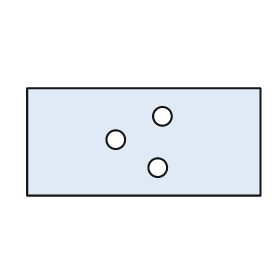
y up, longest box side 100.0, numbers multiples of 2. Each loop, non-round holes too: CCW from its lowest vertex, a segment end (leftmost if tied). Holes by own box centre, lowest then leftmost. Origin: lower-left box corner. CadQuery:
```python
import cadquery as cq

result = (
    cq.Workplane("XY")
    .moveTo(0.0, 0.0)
    .lineTo(100.0, 0.0)
    .lineTo(100.0, 46.0)
    .lineTo(0.0, 46.0)
    .close()
    .moveTo(56.0, 12.0)
    .circle(4.0)
    .moveTo(38.0, 24.0)
    .circle(4.0)
    .moveTo(58.0, 34.0)
    .circle(4.0)
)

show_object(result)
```